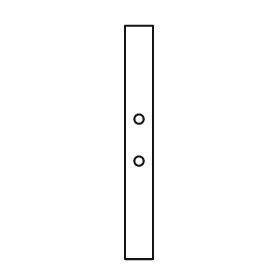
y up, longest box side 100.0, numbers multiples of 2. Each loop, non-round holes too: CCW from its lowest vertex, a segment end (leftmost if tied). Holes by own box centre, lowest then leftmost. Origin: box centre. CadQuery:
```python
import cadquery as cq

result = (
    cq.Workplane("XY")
    .moveTo(-6.0, -50.0)
    .lineTo(6.0, -50.0)
    .lineTo(6.0, 50.0)
    .lineTo(-6.0, 50.0)
    .close()
    .moveTo(0.0, -8.0)
    .circle(2.0)
    .moveTo(0.0, 10.0)
    .circle(2.0)
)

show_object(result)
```